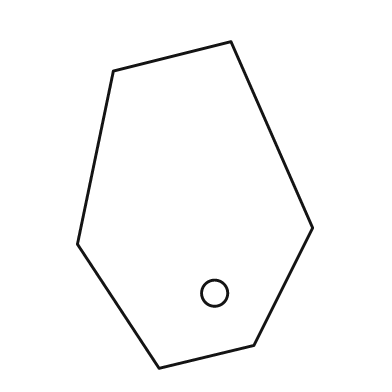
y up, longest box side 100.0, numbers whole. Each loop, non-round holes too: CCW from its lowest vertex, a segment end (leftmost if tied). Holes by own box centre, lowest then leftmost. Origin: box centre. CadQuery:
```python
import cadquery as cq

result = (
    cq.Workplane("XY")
    .moveTo(-11.0, -50.0)
    .lineTo(18.0, -43.0)
    .lineTo(36.0, -7.0)
    .lineTo(11.0, 50.0)
    .lineTo(-25.0, 41.0)
    .lineTo(-36.0, -12.0)
    .close()
    .moveTo(6.0, -27.0)
    .circle(4.0)
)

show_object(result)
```